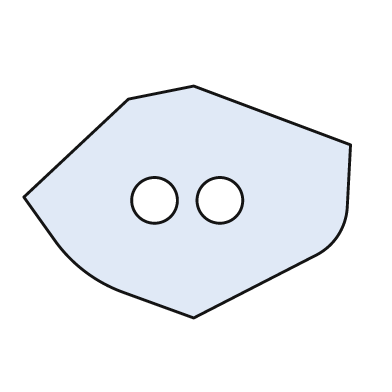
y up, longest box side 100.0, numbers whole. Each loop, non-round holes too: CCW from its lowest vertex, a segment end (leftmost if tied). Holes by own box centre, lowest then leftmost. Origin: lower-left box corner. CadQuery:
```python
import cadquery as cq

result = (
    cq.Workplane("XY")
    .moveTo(52.0, 0.0)
    .lineTo(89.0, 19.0)
    .threePointArc((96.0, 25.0), (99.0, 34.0))
    .lineTo(100.0, 53.0)
    .lineTo(52.0, 71.0)
    .lineTo(32.0, 67.0)
    .lineTo(0.0, 37.0)
    .lineTo(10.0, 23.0)
    .threePointArc((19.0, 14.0), (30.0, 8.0))
    .close()
    .moveTo(40.0, 36.0)
    .circle(7.0)
    .moveTo(60.0, 36.0)
    .circle(7.0)
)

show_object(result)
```